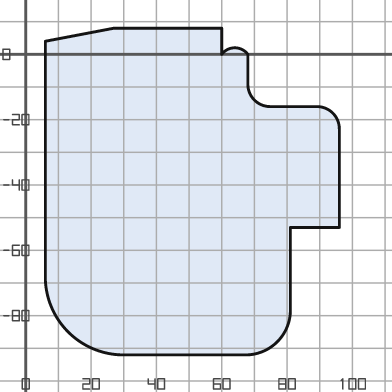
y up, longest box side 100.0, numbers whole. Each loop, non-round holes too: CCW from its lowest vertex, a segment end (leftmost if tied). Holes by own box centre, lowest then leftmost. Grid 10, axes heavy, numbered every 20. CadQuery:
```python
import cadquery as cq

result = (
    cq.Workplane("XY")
    .moveTo(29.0, -92.0)
    .lineTo(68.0, -92.0)
    .threePointArc((77.0, -88.0), (81.0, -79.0))
    .lineTo(81.0, -53.0)
    .lineTo(96.0, -53.0)
    .lineTo(96.0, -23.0)
    .threePointArc((94.0, -18.0), (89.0, -16.0))
    .lineTo(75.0, -16.0)
    .threePointArc((70.0, -14.0), (68.0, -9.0))
    .lineTo(68.0, 0.0)
    .threePointArc((64.0, 2.0), (60.0, 0.0))
    .lineTo(60.0, 8.0)
    .lineTo(27.0, 8.0)
    .lineTo(6.0, 4.0)
    .lineTo(6.0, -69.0)
    .threePointArc((13.0, -85.0), (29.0, -92.0))
    .close()
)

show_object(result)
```